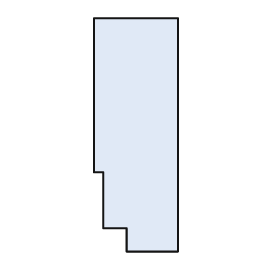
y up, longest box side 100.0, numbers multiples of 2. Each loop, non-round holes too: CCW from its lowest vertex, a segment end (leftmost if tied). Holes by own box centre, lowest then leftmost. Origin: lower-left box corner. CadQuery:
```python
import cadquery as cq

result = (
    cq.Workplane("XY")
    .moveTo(14.0, 0.0)
    .lineTo(36.0, 0.0)
    .lineTo(36.0, 100.0)
    .lineTo(0.0, 100.0)
    .lineTo(0.0, 34.0)
    .lineTo(4.0, 34.0)
    .lineTo(4.0, 10.0)
    .lineTo(14.0, 10.0)
    .close()
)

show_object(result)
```